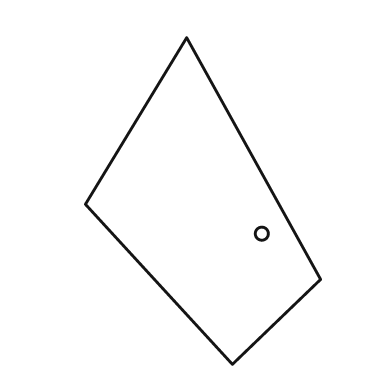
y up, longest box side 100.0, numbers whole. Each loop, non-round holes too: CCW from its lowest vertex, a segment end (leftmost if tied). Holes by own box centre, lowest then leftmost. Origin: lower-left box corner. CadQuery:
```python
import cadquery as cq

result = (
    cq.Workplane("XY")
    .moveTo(45.0, 0.0)
    .lineTo(72.0, 26.0)
    .lineTo(31.0, 100.0)
    .lineTo(0.0, 49.0)
    .close()
    .moveTo(54.0, 40.0)
    .circle(2.0)
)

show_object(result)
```